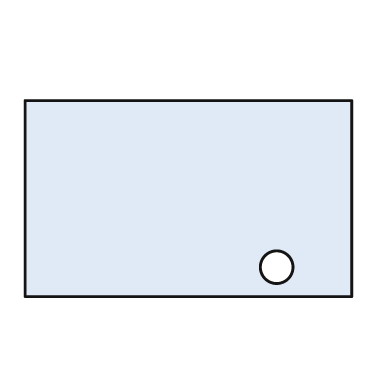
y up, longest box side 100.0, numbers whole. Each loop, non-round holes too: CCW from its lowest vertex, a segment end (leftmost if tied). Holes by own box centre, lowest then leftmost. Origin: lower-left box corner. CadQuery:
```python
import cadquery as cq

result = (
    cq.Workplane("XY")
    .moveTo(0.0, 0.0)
    .lineTo(100.0, 0.0)
    .lineTo(100.0, 60.0)
    .lineTo(0.0, 60.0)
    .close()
    .moveTo(77.0, 9.0)
    .circle(5.0)
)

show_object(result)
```